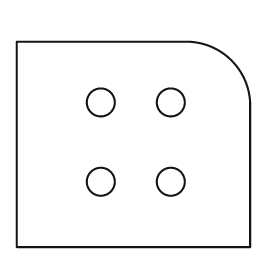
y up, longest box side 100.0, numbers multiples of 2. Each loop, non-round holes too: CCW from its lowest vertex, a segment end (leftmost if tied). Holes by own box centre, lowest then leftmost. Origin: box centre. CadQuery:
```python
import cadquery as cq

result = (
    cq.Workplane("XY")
    .moveTo(-50.0, -44.0)
    .lineTo(50.0, -44.0)
    .lineTo(50.0, 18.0)
    .threePointArc((42.0, 36.0), (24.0, 44.0))
    .lineTo(-50.0, 44.0)
    .close()
    .moveTo(-14.0, -16.0)
    .circle(6.0)
    .moveTo(16.0, -16.0)
    .circle(6.0)
    .moveTo(-14.0, 18.0)
    .circle(6.0)
    .moveTo(16.0, 18.0)
    .circle(6.0)
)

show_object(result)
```